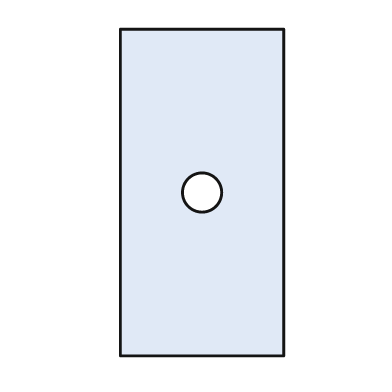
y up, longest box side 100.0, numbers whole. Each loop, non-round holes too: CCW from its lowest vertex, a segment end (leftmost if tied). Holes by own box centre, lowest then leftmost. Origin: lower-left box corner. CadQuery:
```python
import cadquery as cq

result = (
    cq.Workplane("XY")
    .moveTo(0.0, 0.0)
    .lineTo(50.0, 0.0)
    .lineTo(50.0, 100.0)
    .lineTo(0.0, 100.0)
    .close()
    .moveTo(25.0, 50.0)
    .circle(6.0)
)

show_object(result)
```